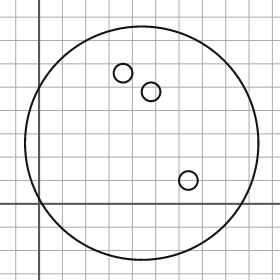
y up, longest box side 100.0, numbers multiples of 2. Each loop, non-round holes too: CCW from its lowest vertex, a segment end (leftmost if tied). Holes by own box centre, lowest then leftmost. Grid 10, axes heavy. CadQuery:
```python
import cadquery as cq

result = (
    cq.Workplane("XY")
    .moveTo(44.0, 26.0)
    .circle(50.0)
    .moveTo(64.0, 10.0)
    .circle(4.0)
    .moveTo(48.0, 48.0)
    .circle(4.0)
    .moveTo(36.0, 56.0)
    .circle(4.0)
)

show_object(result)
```